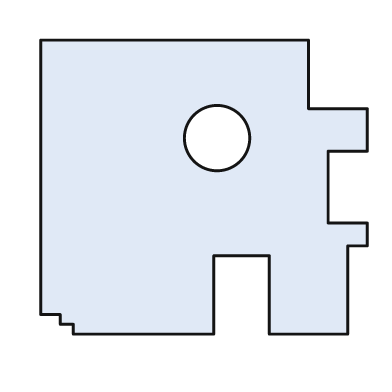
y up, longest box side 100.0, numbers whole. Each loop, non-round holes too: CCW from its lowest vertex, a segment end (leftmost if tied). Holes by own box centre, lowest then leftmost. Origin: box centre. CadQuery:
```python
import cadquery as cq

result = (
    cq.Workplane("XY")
    .moveTo(-40.0, -45.0)
    .lineTo(3.0, -45.0)
    .lineTo(3.0, -21.0)
    .lineTo(20.0, -21.0)
    .lineTo(20.0, -45.0)
    .lineTo(44.0, -45.0)
    .lineTo(44.0, -18.0)
    .lineTo(50.0, -18.0)
    .lineTo(50.0, -11.0)
    .lineTo(38.0, -11.0)
    .lineTo(38.0, 11.0)
    .lineTo(50.0, 11.0)
    .lineTo(50.0, 24.0)
    .lineTo(32.0, 24.0)
    .lineTo(32.0, 45.0)
    .lineTo(-50.0, 45.0)
    .lineTo(-50.0, -39.0)
    .lineTo(-44.0, -39.0)
    .lineTo(-44.0, -42.0)
    .lineTo(-40.0, -42.0)
    .close()
    .moveTo(4.0, 15.0)
    .circle(10.0)
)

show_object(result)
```